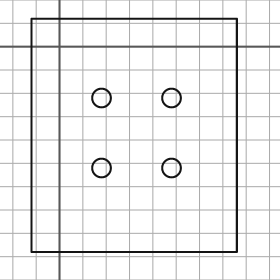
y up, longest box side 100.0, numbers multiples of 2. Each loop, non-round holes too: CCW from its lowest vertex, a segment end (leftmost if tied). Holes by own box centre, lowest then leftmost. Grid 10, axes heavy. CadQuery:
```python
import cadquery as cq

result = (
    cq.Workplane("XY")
    .moveTo(-12.0, -88.0)
    .lineTo(76.0, -88.0)
    .lineTo(76.0, 12.0)
    .lineTo(-12.0, 12.0)
    .close()
    .moveTo(18.0, -52.0)
    .circle(4.0)
    .moveTo(48.0, -52.0)
    .circle(4.0)
    .moveTo(18.0, -22.0)
    .circle(4.0)
    .moveTo(48.0, -22.0)
    .circle(4.0)
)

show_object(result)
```